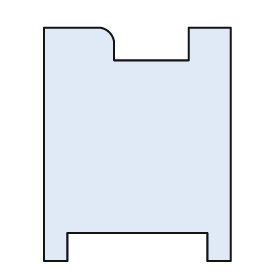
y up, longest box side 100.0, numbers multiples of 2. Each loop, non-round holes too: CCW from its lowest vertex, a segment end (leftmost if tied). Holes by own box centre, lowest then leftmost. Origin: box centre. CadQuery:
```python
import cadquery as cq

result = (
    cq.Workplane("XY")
    .moveTo(-40.0, -50.0)
    .lineTo(-30.0, -50.0)
    .lineTo(-30.0, -38.0)
    .lineTo(30.0, -38.0)
    .lineTo(30.0, -50.0)
    .lineTo(40.0, -50.0)
    .lineTo(40.0, 50.0)
    .lineTo(22.0, 50.0)
    .lineTo(22.0, 36.0)
    .lineTo(-10.0, 36.0)
    .lineTo(-10.0, 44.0)
    .threePointArc((-12.0, 48.0), (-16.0, 50.0))
    .lineTo(-40.0, 50.0)
    .close()
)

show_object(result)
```